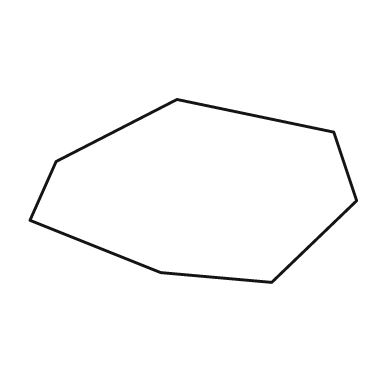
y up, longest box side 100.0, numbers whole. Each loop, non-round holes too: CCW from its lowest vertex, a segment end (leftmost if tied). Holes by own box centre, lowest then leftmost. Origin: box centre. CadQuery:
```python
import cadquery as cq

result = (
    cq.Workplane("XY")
    .moveTo(24.0, -28.0)
    .lineTo(50.0, -3.0)
    .lineTo(43.0, 18.0)
    .lineTo(-5.0, 28.0)
    .lineTo(-42.0, 9.0)
    .lineTo(-50.0, -9.0)
    .lineTo(-10.0, -25.0)
    .close()
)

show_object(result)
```